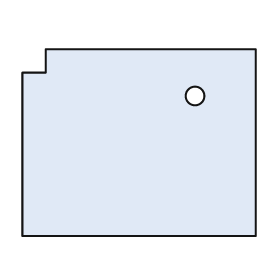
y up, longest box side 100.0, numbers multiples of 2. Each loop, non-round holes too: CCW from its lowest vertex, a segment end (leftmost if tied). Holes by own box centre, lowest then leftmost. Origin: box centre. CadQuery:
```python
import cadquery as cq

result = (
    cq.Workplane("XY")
    .moveTo(-50.0, -40.0)
    .lineTo(50.0, -40.0)
    .lineTo(50.0, 40.0)
    .lineTo(-40.0, 40.0)
    .lineTo(-40.0, 30.0)
    .lineTo(-50.0, 30.0)
    .close()
    .moveTo(24.0, 20.0)
    .circle(4.0)
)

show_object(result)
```